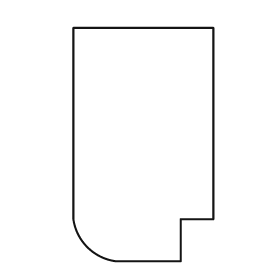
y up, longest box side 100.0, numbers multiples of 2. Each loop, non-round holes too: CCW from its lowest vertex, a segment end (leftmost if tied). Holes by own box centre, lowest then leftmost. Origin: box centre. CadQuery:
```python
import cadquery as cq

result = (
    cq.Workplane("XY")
    .moveTo(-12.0, -50.0)
    .lineTo(16.0, -50.0)
    .lineTo(16.0, -32.0)
    .lineTo(30.0, -32.0)
    .lineTo(30.0, 50.0)
    .lineTo(-30.0, 50.0)
    .lineTo(-30.0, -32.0)
    .threePointArc((-24.0, -44.0), (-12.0, -50.0))
    .close()
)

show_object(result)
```